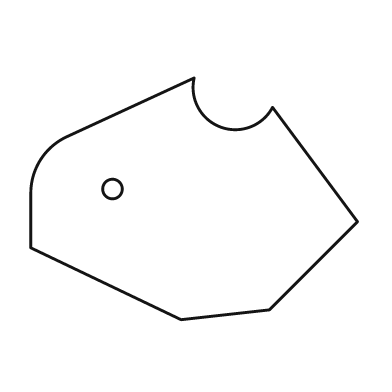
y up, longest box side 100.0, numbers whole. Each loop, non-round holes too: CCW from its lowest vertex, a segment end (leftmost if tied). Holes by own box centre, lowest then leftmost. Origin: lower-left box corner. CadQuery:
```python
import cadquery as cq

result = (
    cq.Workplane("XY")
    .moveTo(46.0, 0.0)
    .lineTo(73.0, 3.0)
    .lineTo(100.0, 30.0)
    .lineTo(74.0, 65.0)
    .threePointArc((58.0, 59.0), (50.0, 74.0))
    .lineTo(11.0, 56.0)
    .threePointArc((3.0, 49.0), (0.0, 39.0))
    .lineTo(0.0, 22.0)
    .close()
    .moveTo(25.0, 40.0)
    .circle(3.0)
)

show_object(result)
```